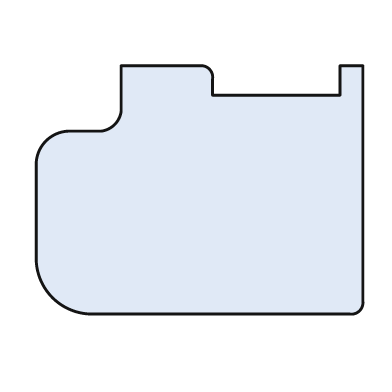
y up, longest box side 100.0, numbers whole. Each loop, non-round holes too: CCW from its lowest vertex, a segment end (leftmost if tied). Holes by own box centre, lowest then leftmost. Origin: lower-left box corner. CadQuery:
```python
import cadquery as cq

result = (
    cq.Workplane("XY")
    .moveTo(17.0, 0.0)
    .lineTo(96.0, 0.0)
    .threePointArc((99.0, 1.0), (100.0, 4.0))
    .lineTo(100.0, 76.0)
    .lineTo(93.0, 76.0)
    .lineTo(93.0, 67.0)
    .lineTo(54.0, 67.0)
    .lineTo(54.0, 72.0)
    .threePointArc((53.0, 75.0), (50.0, 76.0))
    .lineTo(26.0, 76.0)
    .lineTo(26.0, 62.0)
    .threePointArc((24.0, 58.0), (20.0, 56.0))
    .lineTo(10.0, 56.0)
    .threePointArc((3.0, 53.0), (0.0, 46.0))
    .lineTo(0.0, 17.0)
    .threePointArc((5.0, 5.0), (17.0, 0.0))
    .close()
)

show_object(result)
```